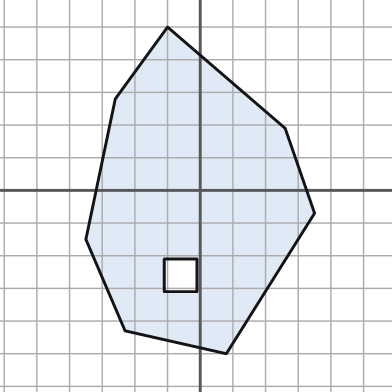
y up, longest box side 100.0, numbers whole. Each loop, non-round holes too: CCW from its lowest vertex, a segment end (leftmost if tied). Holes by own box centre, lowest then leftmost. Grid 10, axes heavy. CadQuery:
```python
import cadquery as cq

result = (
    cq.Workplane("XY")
    .moveTo(8.0, -50.0)
    .lineTo(35.0, -7.0)
    .lineTo(26.0, 19.0)
    .lineTo(-10.0, 50.0)
    .lineTo(-26.0, 28.0)
    .lineTo(-35.0, -15.0)
    .lineTo(-23.0, -43.0)
    .close()
    .moveTo(-11.0, -31.0)
    .lineTo(-1.0, -31.0)
    .lineTo(-1.0, -21.0)
    .lineTo(-11.0, -21.0)
    .close()
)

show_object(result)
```